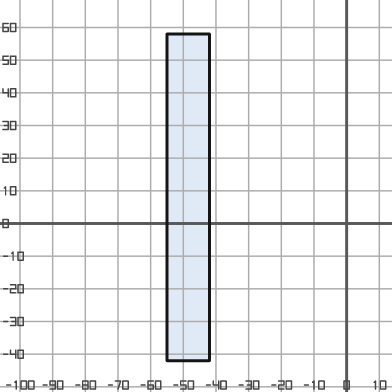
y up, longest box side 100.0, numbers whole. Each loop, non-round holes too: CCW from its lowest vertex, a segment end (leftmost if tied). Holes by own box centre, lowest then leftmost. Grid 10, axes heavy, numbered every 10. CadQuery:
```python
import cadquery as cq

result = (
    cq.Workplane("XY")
    .moveTo(-55.0, -42.0)
    .lineTo(-42.0, -42.0)
    .lineTo(-42.0, 58.0)
    .lineTo(-55.0, 58.0)
    .close()
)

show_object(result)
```